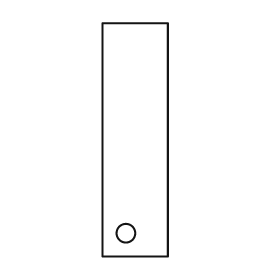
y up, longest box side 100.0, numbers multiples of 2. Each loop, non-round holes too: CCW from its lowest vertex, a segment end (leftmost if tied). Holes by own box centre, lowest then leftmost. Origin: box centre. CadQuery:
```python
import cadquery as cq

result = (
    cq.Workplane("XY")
    .moveTo(-14.0, -50.0)
    .lineTo(14.0, -50.0)
    .lineTo(14.0, 50.0)
    .lineTo(-14.0, 50.0)
    .close()
    .moveTo(-4.0, -40.0)
    .circle(4.0)
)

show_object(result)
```